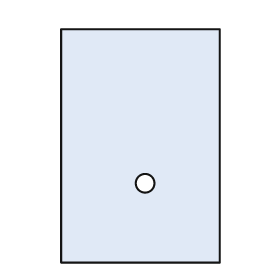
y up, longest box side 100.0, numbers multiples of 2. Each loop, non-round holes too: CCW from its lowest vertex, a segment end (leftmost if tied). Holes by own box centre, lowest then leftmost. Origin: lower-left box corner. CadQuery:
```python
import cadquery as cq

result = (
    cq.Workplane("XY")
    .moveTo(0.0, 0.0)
    .lineTo(68.0, 0.0)
    .lineTo(68.0, 100.0)
    .lineTo(0.0, 100.0)
    .close()
    .moveTo(36.0, 34.0)
    .circle(4.0)
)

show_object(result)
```